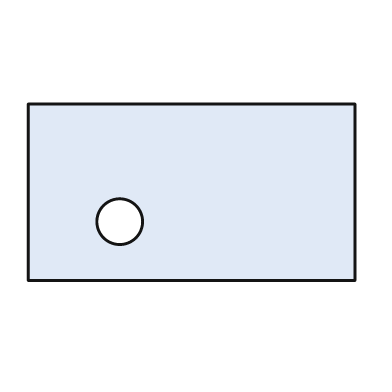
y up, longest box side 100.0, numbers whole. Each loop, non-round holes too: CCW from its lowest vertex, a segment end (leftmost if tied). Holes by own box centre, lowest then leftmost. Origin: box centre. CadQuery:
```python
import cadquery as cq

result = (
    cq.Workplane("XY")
    .moveTo(-50.0, -27.0)
    .lineTo(50.0, -27.0)
    .lineTo(50.0, 27.0)
    .lineTo(-50.0, 27.0)
    .close()
    .moveTo(-22.0, -9.0)
    .circle(7.0)
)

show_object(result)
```